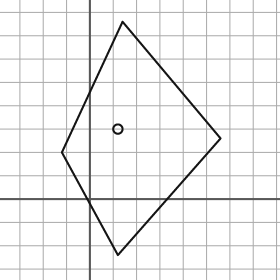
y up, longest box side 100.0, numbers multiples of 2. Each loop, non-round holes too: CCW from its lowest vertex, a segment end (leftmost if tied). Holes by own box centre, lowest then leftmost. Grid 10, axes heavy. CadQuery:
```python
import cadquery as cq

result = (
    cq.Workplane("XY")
    .moveTo(12.0, -24.0)
    .lineTo(56.0, 26.0)
    .lineTo(14.0, 76.0)
    .lineTo(-12.0, 20.0)
    .close()
    .moveTo(12.0, 30.0)
    .circle(2.0)
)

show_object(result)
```